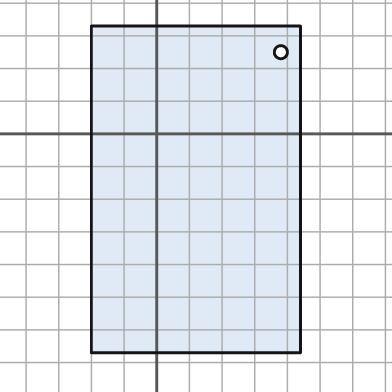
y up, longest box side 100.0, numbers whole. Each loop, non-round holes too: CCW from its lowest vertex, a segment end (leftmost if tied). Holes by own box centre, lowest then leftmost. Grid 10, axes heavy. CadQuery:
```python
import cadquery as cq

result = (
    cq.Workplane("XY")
    .moveTo(-20.0, -67.0)
    .lineTo(44.0, -67.0)
    .lineTo(44.0, 33.0)
    .lineTo(-20.0, 33.0)
    .close()
    .moveTo(38.0, 25.0)
    .circle(2.0)
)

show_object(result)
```